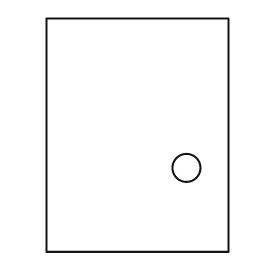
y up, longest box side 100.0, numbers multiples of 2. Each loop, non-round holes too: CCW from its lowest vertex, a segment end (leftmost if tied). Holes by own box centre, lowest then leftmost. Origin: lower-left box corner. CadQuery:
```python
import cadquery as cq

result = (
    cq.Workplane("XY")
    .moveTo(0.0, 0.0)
    .lineTo(78.0, 0.0)
    .lineTo(78.0, 100.0)
    .lineTo(0.0, 100.0)
    .close()
    .moveTo(60.0, 36.0)
    .circle(6.0)
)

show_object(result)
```